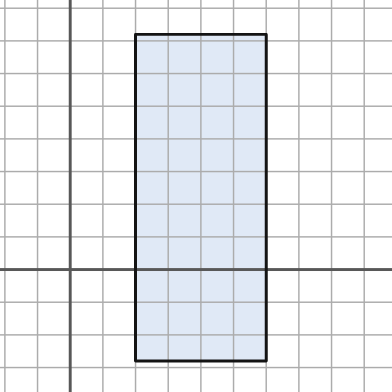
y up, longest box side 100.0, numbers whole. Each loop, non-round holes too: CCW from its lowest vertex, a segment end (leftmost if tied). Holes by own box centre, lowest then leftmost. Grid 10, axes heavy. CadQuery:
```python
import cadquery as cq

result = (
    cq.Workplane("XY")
    .moveTo(20.0, -28.0)
    .lineTo(60.0, -28.0)
    .lineTo(60.0, 72.0)
    .lineTo(20.0, 72.0)
    .close()
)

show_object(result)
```